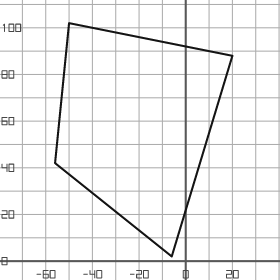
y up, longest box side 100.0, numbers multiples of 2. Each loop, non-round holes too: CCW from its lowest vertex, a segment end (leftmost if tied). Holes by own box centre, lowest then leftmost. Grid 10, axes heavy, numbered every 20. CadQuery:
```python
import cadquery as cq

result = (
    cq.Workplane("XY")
    .moveTo(-6.0, 2.0)
    .lineTo(20.0, 88.0)
    .lineTo(-50.0, 102.0)
    .lineTo(-56.0, 42.0)
    .close()
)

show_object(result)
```